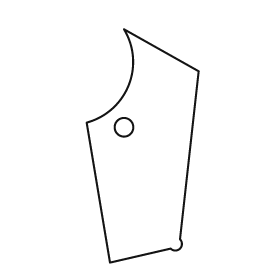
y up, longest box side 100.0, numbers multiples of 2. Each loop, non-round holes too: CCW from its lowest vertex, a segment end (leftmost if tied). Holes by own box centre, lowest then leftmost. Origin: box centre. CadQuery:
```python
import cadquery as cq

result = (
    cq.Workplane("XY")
    .moveTo(-14.0, -50.0)
    .lineTo(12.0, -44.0)
    .threePointArc((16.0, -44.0), (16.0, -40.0))
    .lineTo(24.0, 32.0)
    .lineTo(-8.0, 50.0)
    .threePointArc((-6.0, 26.0), (-24.0, 10.0))
    .close()
    .moveTo(-8.0, 8.0)
    .circle(4.0)
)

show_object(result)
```